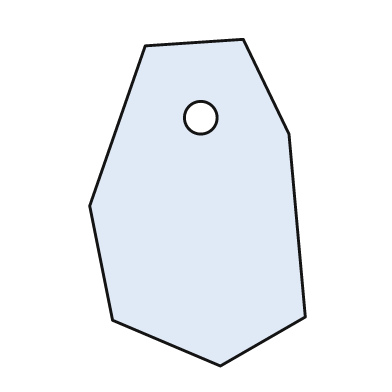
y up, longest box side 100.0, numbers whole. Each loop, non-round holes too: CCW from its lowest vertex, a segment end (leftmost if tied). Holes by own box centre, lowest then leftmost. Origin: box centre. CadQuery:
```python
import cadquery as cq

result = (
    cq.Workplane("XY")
    .moveTo(7.0, -50.0)
    .lineTo(33.0, -35.0)
    .lineTo(28.0, 21.0)
    .lineTo(14.0, 50.0)
    .lineTo(-16.0, 48.0)
    .lineTo(-33.0, -1.0)
    .lineTo(-26.0, -36.0)
    .close()
    .moveTo(1.0, 26.0)
    .circle(5.0)
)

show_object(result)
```